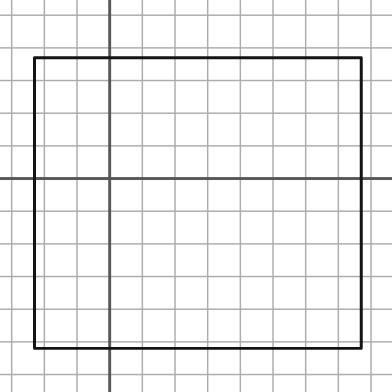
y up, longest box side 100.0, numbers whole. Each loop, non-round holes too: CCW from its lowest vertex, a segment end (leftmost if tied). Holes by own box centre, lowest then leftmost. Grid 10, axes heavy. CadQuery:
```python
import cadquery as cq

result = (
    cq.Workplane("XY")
    .moveTo(-23.0, -52.0)
    .lineTo(77.0, -52.0)
    .lineTo(77.0, 37.0)
    .lineTo(-23.0, 37.0)
    .close()
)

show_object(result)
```